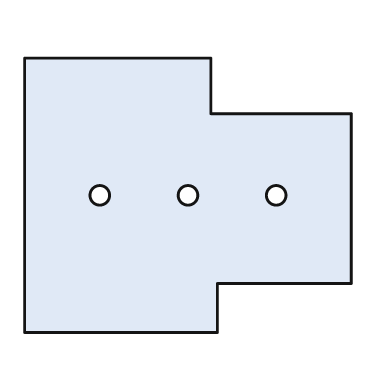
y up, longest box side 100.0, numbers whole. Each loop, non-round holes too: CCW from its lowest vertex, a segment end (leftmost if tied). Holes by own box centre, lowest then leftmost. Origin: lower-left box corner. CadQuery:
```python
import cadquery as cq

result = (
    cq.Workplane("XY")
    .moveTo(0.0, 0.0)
    .lineTo(59.0, 0.0)
    .lineTo(59.0, 15.0)
    .lineTo(100.0, 15.0)
    .lineTo(100.0, 67.0)
    .lineTo(57.0, 67.0)
    .lineTo(57.0, 84.0)
    .lineTo(0.0, 84.0)
    .close()
    .moveTo(23.0, 42.0)
    .circle(3.0)
    .moveTo(50.0, 42.0)
    .circle(3.0)
    .moveTo(77.0, 42.0)
    .circle(3.0)
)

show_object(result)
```